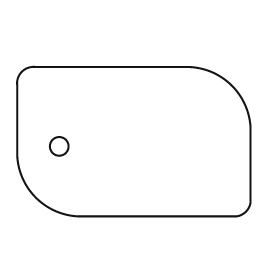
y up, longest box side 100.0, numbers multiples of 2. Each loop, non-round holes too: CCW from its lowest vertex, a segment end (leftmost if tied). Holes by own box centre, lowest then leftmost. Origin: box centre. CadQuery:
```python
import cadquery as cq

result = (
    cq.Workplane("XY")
    .moveTo(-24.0, -32.0)
    .lineTo(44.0, -32.0)
    .threePointArc((48.0, -30.0), (50.0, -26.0))
    .lineTo(50.0, 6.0)
    .threePointArc((42.0, 24.0), (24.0, 32.0))
    .lineTo(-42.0, 32.0)
    .threePointArc((-48.0, 30.0), (-50.0, 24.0))
    .lineTo(-50.0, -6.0)
    .threePointArc((-42.0, -24.0), (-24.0, -32.0))
    .close()
    .moveTo(-32.0, -2.0)
    .circle(4.0)
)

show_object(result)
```